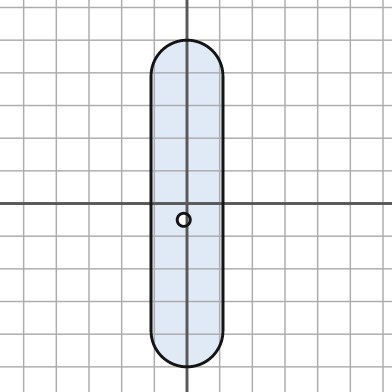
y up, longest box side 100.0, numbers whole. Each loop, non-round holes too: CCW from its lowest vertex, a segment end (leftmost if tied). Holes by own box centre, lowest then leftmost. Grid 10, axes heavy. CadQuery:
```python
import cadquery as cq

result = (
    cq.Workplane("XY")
    .moveTo(-11.0, -39.0)
    .threePointArc((0.0, -50.0), (11.0, -39.0))
    .lineTo(11.0, 39.0)
    .threePointArc((0.0, 50.0), (-11.0, 39.0))
    .close()
    .moveTo(-1.0, -5.0)
    .circle(2.0)
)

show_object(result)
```